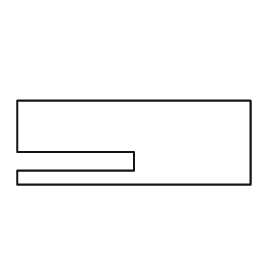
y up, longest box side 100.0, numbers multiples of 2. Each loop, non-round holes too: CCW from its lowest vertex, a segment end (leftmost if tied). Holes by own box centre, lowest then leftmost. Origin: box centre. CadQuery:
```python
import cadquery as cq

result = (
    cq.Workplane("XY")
    .moveTo(-50.0, -18.0)
    .lineTo(50.0, -18.0)
    .lineTo(50.0, 18.0)
    .lineTo(-50.0, 18.0)
    .lineTo(-50.0, -4.0)
    .lineTo(0.0, -4.0)
    .lineTo(0.0, -12.0)
    .lineTo(-50.0, -12.0)
    .close()
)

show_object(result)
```